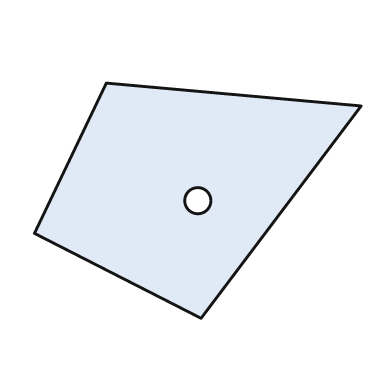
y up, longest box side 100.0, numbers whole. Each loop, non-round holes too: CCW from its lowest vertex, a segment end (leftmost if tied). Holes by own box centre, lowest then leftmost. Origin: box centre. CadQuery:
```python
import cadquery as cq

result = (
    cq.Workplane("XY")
    .moveTo(1.0, -36.0)
    .lineTo(50.0, 29.0)
    .lineTo(-28.0, 36.0)
    .lineTo(-50.0, -10.0)
    .close()
    .moveTo(0.0, 0.0)
    .circle(4.0)
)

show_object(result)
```